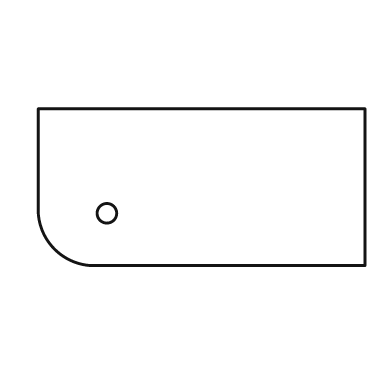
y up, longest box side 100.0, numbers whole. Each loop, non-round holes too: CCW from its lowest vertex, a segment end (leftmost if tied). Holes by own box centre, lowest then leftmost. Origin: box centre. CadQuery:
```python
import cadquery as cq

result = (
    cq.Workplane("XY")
    .moveTo(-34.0, -24.0)
    .lineTo(50.0, -24.0)
    .lineTo(50.0, 24.0)
    .lineTo(-50.0, 24.0)
    .lineTo(-50.0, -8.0)
    .threePointArc((-45.0, -19.0), (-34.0, -24.0))
    .close()
    .moveTo(-29.0, -8.0)
    .circle(3.0)
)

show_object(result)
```